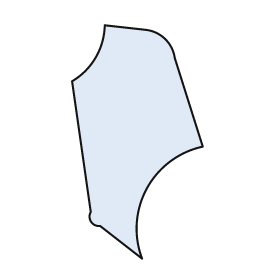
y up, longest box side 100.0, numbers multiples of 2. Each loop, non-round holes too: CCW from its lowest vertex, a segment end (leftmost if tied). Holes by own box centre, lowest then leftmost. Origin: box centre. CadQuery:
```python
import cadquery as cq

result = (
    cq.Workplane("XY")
    .moveTo(2.0, -50.0)
    .threePointArc((4.0, -20.0), (28.0, -2.0))
    .lineTo(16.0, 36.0)
    .threePointArc((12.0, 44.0), (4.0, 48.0))
    .lineTo(-14.0, 50.0)
    .threePointArc((-18.0, 36.0), (-28.0, 26.0))
    .lineTo(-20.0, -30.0)
    .threePointArc((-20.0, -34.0), (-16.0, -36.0))
    .close()
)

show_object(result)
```